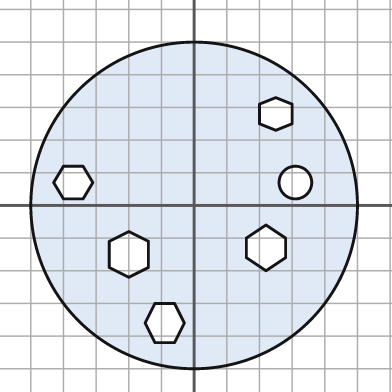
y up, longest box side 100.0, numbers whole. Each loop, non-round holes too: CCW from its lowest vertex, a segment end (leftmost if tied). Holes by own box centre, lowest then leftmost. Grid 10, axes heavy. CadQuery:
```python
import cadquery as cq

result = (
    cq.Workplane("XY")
    .moveTo(0.0, 0.0)
    .circle(50.0)
    .moveTo(-12.0, -42.0)
    .lineTo(-6.0, -42.0)
    .lineTo(-3.0, -36.0)
    .lineTo(-6.0, -30.0)
    .lineTo(-12.0, -30.0)
    .lineTo(-15.0, -36.0)
    .close()
    .moveTo(-20.0, -22.0)
    .lineTo(-14.0, -19.0)
    .lineTo(-14.0, -11.0)
    .lineTo(-20.0, -8.0)
    .lineTo(-26.0, -11.0)
    .lineTo(-26.0, -19.0)
    .close()
    .moveTo(22.0, -20.0)
    .lineTo(28.0, -16.0)
    .lineTo(28.0, -10.0)
    .lineTo(22.0, -6.0)
    .lineTo(16.0, -10.0)
    .lineTo(16.0, -16.0)
    .close()
    .moveTo(-40.0, 2.0)
    .lineTo(-34.0, 2.0)
    .lineTo(-31.0, 7.0)
    .lineTo(-34.0, 12.0)
    .lineTo(-40.0, 12.0)
    .lineTo(-43.0, 7.0)
    .close()
    .moveTo(31.0, 7.0)
    .circle(5.0)
    .moveTo(25.0, 23.0)
    .lineTo(30.0, 25.0)
    .lineTo(30.0, 31.0)
    .lineTo(25.0, 33.0)
    .lineTo(20.0, 31.0)
    .lineTo(20.0, 25.0)
    .close()
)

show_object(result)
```